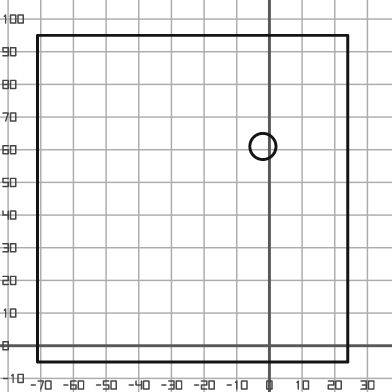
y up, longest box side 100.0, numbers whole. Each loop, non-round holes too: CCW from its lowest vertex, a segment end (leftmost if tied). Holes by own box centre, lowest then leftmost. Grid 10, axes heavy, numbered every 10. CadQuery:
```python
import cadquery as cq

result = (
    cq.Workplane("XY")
    .moveTo(-71.0, -5.0)
    .lineTo(24.0, -5.0)
    .lineTo(24.0, 95.0)
    .lineTo(-71.0, 95.0)
    .close()
    .moveTo(-2.0, 61.0)
    .circle(4.0)
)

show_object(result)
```